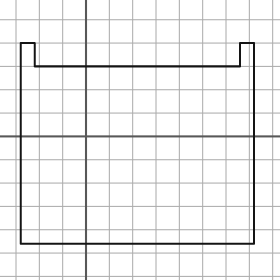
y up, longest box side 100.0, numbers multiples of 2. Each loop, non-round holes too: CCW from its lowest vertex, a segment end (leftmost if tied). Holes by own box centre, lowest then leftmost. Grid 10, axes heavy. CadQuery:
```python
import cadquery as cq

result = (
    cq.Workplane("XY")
    .moveTo(-28.0, -46.0)
    .lineTo(72.0, -46.0)
    .lineTo(72.0, 40.0)
    .lineTo(66.0, 40.0)
    .lineTo(66.0, 30.0)
    .lineTo(-22.0, 30.0)
    .lineTo(-22.0, 40.0)
    .lineTo(-28.0, 40.0)
    .close()
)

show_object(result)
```